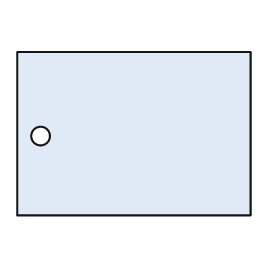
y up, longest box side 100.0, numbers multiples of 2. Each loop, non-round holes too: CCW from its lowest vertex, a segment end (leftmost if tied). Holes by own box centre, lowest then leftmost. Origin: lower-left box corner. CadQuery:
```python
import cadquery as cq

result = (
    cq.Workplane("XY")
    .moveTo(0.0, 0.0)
    .lineTo(100.0, 0.0)
    .lineTo(100.0, 70.0)
    .lineTo(0.0, 70.0)
    .close()
    .moveTo(10.0, 34.0)
    .circle(4.0)
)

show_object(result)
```